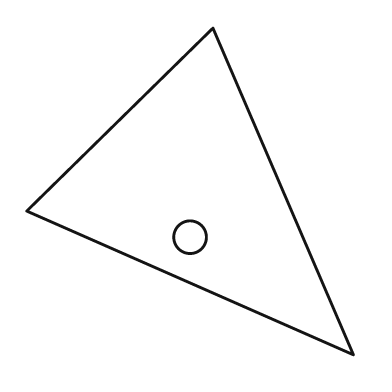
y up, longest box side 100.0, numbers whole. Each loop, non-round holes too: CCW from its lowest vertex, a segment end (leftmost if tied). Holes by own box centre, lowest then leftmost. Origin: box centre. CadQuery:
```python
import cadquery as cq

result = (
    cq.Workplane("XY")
    .moveTo(50.0, -50.0)
    .lineTo(7.0, 50.0)
    .lineTo(-50.0, -6.0)
    .close()
    .moveTo(0.0, -14.0)
    .circle(5.0)
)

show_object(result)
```